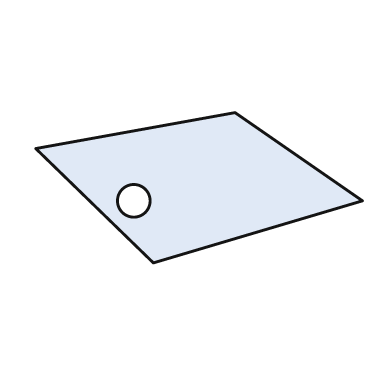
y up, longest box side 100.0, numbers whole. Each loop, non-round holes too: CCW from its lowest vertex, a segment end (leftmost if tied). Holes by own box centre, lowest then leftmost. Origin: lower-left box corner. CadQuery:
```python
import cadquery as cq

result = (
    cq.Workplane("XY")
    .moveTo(36.0, 0.0)
    .lineTo(100.0, 19.0)
    .lineTo(61.0, 46.0)
    .lineTo(0.0, 35.0)
    .close()
    .moveTo(30.0, 19.0)
    .circle(5.0)
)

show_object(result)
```